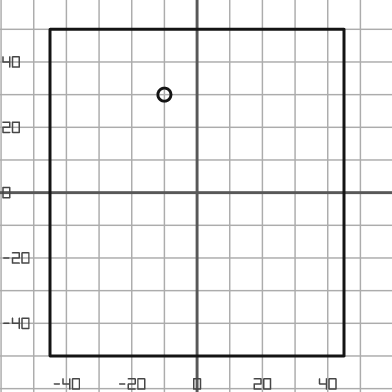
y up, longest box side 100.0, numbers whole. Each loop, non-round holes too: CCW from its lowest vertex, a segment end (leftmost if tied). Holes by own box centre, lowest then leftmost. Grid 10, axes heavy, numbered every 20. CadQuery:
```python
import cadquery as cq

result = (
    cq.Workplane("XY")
    .moveTo(-45.0, -50.0)
    .lineTo(45.0, -50.0)
    .lineTo(45.0, 50.0)
    .lineTo(-45.0, 50.0)
    .close()
    .moveTo(-10.0, 30.0)
    .circle(2.0)
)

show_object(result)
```